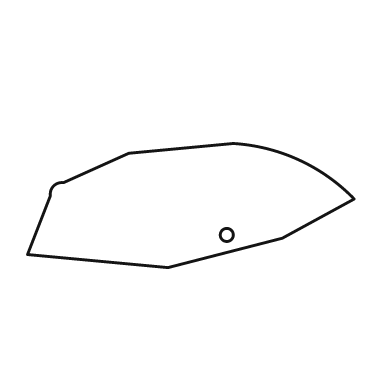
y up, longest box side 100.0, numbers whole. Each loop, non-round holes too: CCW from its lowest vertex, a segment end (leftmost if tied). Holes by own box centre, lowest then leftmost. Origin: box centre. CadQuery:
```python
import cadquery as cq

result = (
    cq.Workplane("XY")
    .moveTo(-7.0, -19.0)
    .lineTo(28.0, -10.0)
    .lineTo(50.0, 2.0)
    .threePointArc((33.0, 14.0), (13.0, 19.0))
    .lineTo(-19.0, 16.0)
    .lineTo(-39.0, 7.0)
    .threePointArc((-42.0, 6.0), (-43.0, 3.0))
    .lineTo(-50.0, -15.0)
    .close()
    .moveTo(11.0, -9.0)
    .circle(2.0)
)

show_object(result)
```